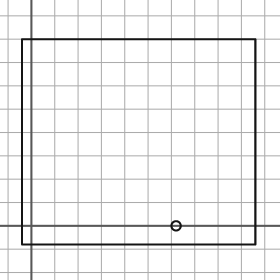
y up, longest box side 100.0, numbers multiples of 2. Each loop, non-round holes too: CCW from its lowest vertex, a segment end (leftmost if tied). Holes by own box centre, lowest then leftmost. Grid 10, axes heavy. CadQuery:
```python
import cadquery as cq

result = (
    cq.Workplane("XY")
    .moveTo(-4.0, -8.0)
    .lineTo(96.0, -8.0)
    .lineTo(96.0, 80.0)
    .lineTo(-4.0, 80.0)
    .close()
    .moveTo(62.0, 0.0)
    .circle(2.0)
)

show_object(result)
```